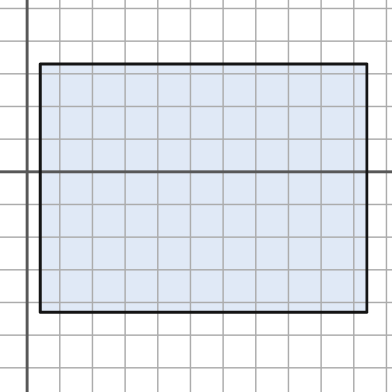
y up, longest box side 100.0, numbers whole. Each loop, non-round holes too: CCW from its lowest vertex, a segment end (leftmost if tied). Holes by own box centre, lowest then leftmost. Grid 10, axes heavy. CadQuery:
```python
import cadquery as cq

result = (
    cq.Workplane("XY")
    .moveTo(4.0, -43.0)
    .lineTo(104.0, -43.0)
    .lineTo(104.0, 33.0)
    .lineTo(4.0, 33.0)
    .close()
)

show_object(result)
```